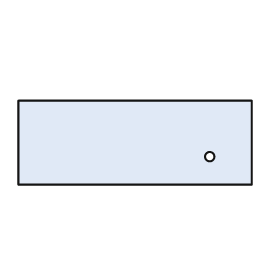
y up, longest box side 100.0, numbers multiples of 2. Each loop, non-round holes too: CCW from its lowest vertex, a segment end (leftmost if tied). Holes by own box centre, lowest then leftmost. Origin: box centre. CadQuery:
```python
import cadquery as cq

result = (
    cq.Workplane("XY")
    .moveTo(-50.0, -18.0)
    .lineTo(50.0, -18.0)
    .lineTo(50.0, 18.0)
    .lineTo(-50.0, 18.0)
    .close()
    .moveTo(32.0, -6.0)
    .circle(2.0)
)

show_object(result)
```